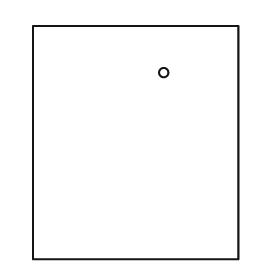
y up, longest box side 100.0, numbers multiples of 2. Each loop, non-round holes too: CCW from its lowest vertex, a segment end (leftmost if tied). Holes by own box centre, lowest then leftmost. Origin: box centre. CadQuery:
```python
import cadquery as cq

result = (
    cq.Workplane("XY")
    .moveTo(-44.0, -50.0)
    .lineTo(44.0, -50.0)
    .lineTo(44.0, 50.0)
    .lineTo(-44.0, 50.0)
    .close()
    .moveTo(12.0, 30.0)
    .circle(2.0)
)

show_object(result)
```